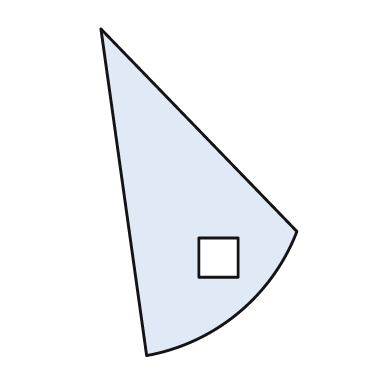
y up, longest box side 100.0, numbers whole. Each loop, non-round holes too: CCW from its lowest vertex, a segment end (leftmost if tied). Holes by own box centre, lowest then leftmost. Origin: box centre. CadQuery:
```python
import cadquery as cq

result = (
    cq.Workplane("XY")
    .moveTo(-16.0, -50.0)
    .threePointArc((12.0, -37.0), (30.0, -12.0))
    .lineTo(-30.0, 50.0)
    .close()
    .moveTo(0.0, -26.0)
    .lineTo(12.0, -26.0)
    .lineTo(12.0, -14.0)
    .lineTo(0.0, -14.0)
    .close()
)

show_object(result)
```